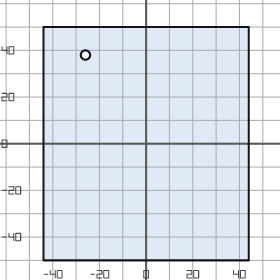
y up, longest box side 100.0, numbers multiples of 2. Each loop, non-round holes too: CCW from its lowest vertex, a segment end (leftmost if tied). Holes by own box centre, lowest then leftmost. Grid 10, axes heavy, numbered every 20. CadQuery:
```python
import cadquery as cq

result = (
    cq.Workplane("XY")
    .moveTo(-44.0, -50.0)
    .lineTo(44.0, -50.0)
    .lineTo(44.0, 50.0)
    .lineTo(-44.0, 50.0)
    .close()
    .moveTo(-26.0, 38.0)
    .circle(2.0)
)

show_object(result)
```